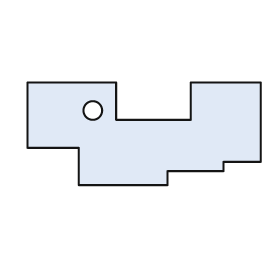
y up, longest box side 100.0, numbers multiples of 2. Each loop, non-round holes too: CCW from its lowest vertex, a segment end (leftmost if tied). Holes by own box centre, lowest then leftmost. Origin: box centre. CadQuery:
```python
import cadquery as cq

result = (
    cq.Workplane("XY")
    .moveTo(-28.0, -22.0)
    .lineTo(10.0, -22.0)
    .lineTo(10.0, -16.0)
    .lineTo(34.0, -16.0)
    .lineTo(34.0, -12.0)
    .lineTo(50.0, -12.0)
    .lineTo(50.0, 22.0)
    .lineTo(20.0, 22.0)
    .lineTo(20.0, 6.0)
    .lineTo(-12.0, 6.0)
    .lineTo(-12.0, 22.0)
    .lineTo(-50.0, 22.0)
    .lineTo(-50.0, -6.0)
    .lineTo(-28.0, -6.0)
    .close()
    .moveTo(-22.0, 10.0)
    .circle(4.0)
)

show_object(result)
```